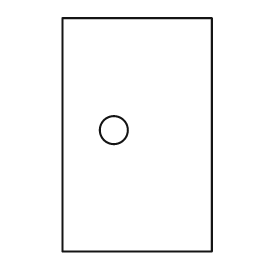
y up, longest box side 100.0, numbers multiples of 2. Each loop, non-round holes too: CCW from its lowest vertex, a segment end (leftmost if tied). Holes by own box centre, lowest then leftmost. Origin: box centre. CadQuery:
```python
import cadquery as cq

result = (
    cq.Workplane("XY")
    .moveTo(-32.0, -50.0)
    .lineTo(32.0, -50.0)
    .lineTo(32.0, 50.0)
    .lineTo(-32.0, 50.0)
    .close()
    .moveTo(-10.0, 2.0)
    .circle(6.0)
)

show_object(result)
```